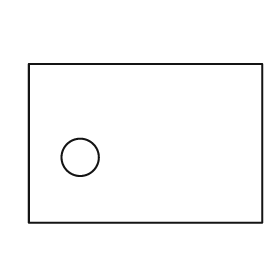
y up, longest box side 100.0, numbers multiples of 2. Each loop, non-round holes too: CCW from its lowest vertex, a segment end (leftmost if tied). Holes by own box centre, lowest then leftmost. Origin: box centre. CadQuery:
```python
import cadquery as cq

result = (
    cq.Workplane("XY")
    .moveTo(-50.0, -34.0)
    .lineTo(50.0, -34.0)
    .lineTo(50.0, 34.0)
    .lineTo(-50.0, 34.0)
    .close()
    .moveTo(-28.0, -6.0)
    .circle(8.0)
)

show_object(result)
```